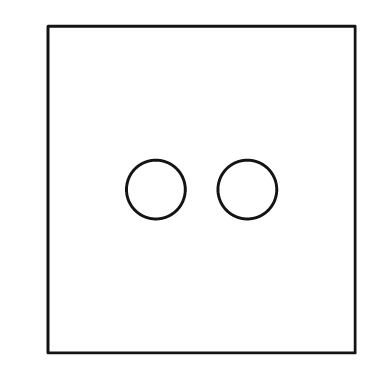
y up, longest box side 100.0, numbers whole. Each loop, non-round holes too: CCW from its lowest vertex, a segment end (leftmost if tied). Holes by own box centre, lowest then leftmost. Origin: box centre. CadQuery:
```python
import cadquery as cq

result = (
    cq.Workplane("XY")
    .moveTo(-47.0, -50.0)
    .lineTo(47.0, -50.0)
    .lineTo(47.0, 50.0)
    .lineTo(-47.0, 50.0)
    .close()
    .moveTo(-14.0, 0.0)
    .circle(9.0)
    .moveTo(14.0, 0.0)
    .circle(9.0)
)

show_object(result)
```